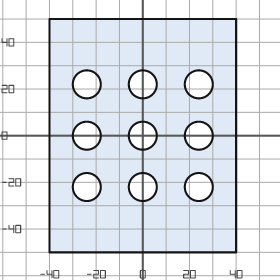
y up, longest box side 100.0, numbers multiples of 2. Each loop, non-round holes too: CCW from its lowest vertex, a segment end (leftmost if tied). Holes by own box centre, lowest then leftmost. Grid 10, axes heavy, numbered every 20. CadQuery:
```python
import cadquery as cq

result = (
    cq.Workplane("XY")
    .moveTo(-40.0, -50.0)
    .lineTo(40.0, -50.0)
    .lineTo(40.0, 50.0)
    .lineTo(-40.0, 50.0)
    .close()
    .moveTo(-24.0, -22.0)
    .circle(6.0)
    .moveTo(0.0, -22.0)
    .circle(6.0)
    .moveTo(24.0, -22.0)
    .circle(6.0)
    .moveTo(-24.0, 0.0)
    .circle(6.0)
    .moveTo(0.0, 0.0)
    .circle(6.0)
    .moveTo(24.0, 0.0)
    .circle(6.0)
    .moveTo(-24.0, 22.0)
    .circle(6.0)
    .moveTo(0.0, 22.0)
    .circle(6.0)
    .moveTo(24.0, 22.0)
    .circle(6.0)
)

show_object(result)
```